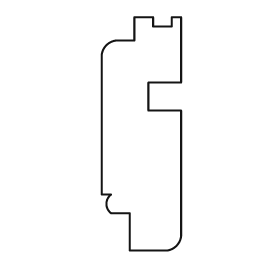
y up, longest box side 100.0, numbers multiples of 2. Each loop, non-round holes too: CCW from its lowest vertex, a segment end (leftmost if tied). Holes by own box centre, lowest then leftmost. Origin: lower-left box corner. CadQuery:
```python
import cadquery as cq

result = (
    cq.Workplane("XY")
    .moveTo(12.0, 0.0)
    .lineTo(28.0, 0.0)
    .threePointArc((32.0, 2.0), (34.0, 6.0))
    .lineTo(34.0, 60.0)
    .lineTo(20.0, 60.0)
    .lineTo(20.0, 72.0)
    .lineTo(34.0, 72.0)
    .lineTo(34.0, 100.0)
    .lineTo(30.0, 100.0)
    .lineTo(30.0, 96.0)
    .lineTo(22.0, 96.0)
    .lineTo(22.0, 100.0)
    .lineTo(14.0, 100.0)
    .lineTo(14.0, 90.0)
    .lineTo(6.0, 90.0)
    .threePointArc((2.0, 88.0), (0.0, 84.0))
    .lineTo(0.0, 24.0)
    .lineTo(4.0, 24.0)
    .threePointArc((2.0, 20.0), (4.0, 16.0))
    .lineTo(12.0, 16.0)
    .close()
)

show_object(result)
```